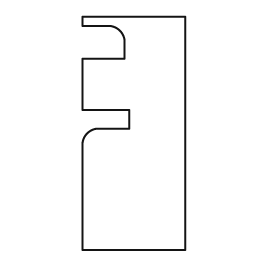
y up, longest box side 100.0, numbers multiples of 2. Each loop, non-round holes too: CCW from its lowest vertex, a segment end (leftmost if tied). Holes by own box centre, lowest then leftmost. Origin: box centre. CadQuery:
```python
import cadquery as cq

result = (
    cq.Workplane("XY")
    .moveTo(-22.0, -50.0)
    .lineTo(22.0, -50.0)
    .lineTo(22.0, 50.0)
    .lineTo(-22.0, 50.0)
    .lineTo(-22.0, 46.0)
    .lineTo(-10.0, 46.0)
    .threePointArc((-6.0, 44.0), (-4.0, 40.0))
    .lineTo(-4.0, 32.0)
    .lineTo(-22.0, 32.0)
    .lineTo(-22.0, 10.0)
    .lineTo(-2.0, 10.0)
    .lineTo(-2.0, 2.0)
    .lineTo(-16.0, 2.0)
    .threePointArc((-20.0, 0.0), (-22.0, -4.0))
    .close()
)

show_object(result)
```